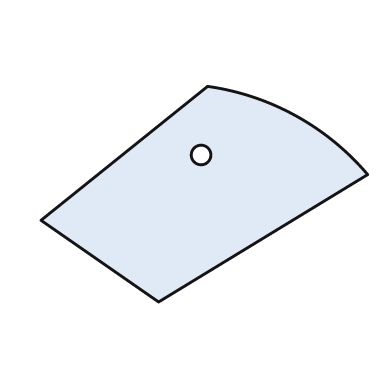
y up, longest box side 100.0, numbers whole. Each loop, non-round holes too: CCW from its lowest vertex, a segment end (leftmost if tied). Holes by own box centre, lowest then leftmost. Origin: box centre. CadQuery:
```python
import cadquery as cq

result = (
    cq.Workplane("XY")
    .moveTo(-14.0, -33.0)
    .lineTo(50.0, 6.0)
    .threePointArc((28.0, 24.0), (1.0, 33.0))
    .lineTo(-50.0, -8.0)
    .close()
    .moveTo(-1.0, 12.0)
    .circle(3.0)
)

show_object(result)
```